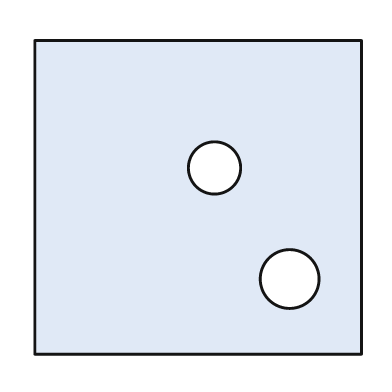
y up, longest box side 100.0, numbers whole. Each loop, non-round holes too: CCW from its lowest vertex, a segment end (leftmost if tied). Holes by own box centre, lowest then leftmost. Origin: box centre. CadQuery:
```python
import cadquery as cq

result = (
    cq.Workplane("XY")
    .moveTo(-50.0, -48.0)
    .lineTo(50.0, -48.0)
    .lineTo(50.0, 48.0)
    .lineTo(-50.0, 48.0)
    .close()
    .moveTo(28.0, -25.0)
    .circle(9.0)
    .moveTo(5.0, 9.0)
    .circle(8.0)
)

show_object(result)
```